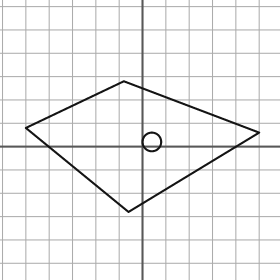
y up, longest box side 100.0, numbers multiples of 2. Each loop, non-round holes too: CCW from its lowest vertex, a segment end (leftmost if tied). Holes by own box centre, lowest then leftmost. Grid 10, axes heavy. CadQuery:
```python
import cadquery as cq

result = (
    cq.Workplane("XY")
    .moveTo(-6.0, -28.0)
    .lineTo(50.0, 6.0)
    .lineTo(-8.0, 28.0)
    .lineTo(-50.0, 8.0)
    .close()
    .moveTo(4.0, 2.0)
    .circle(4.0)
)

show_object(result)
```